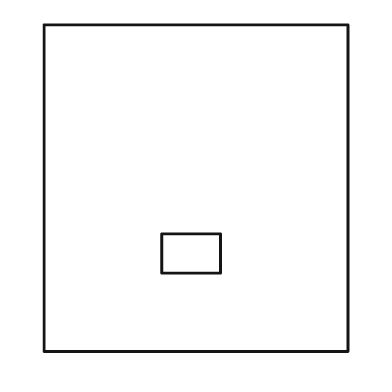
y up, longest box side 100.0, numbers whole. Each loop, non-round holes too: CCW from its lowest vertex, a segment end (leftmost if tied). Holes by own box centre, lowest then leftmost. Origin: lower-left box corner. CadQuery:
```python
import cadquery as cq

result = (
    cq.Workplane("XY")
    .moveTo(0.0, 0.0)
    .lineTo(93.0, 0.0)
    .lineTo(93.0, 100.0)
    .lineTo(0.0, 100.0)
    .close()
    .moveTo(36.0, 24.0)
    .lineTo(54.0, 24.0)
    .lineTo(54.0, 36.0)
    .lineTo(36.0, 36.0)
    .close()
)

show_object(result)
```